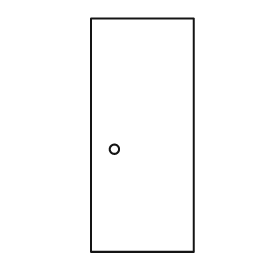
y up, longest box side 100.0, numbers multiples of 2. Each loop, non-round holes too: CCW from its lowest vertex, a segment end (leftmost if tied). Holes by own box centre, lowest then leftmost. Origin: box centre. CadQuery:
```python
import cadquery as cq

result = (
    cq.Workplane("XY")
    .moveTo(-22.0, -50.0)
    .lineTo(22.0, -50.0)
    .lineTo(22.0, 50.0)
    .lineTo(-22.0, 50.0)
    .close()
    .moveTo(-12.0, -6.0)
    .circle(2.0)
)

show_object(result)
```